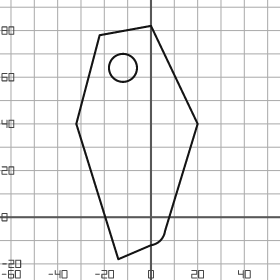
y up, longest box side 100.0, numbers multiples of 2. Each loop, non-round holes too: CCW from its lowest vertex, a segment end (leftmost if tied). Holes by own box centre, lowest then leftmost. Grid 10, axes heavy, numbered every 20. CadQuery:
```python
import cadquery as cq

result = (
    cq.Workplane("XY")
    .moveTo(-14.0, -18.0)
    .lineTo(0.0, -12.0)
    .threePointArc((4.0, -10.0), (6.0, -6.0))
    .lineTo(20.0, 40.0)
    .lineTo(0.0, 82.0)
    .lineTo(-22.0, 78.0)
    .lineTo(-32.0, 40.0)
    .close()
    .moveTo(-12.0, 64.0)
    .circle(6.0)
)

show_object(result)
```